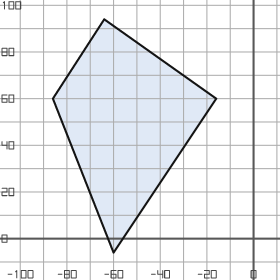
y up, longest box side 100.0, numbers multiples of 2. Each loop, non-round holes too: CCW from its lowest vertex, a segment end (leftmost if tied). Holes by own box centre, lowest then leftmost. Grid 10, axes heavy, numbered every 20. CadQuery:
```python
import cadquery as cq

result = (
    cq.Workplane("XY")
    .moveTo(-60.0, -6.0)
    .lineTo(-16.0, 60.0)
    .lineTo(-64.0, 94.0)
    .lineTo(-86.0, 60.0)
    .close()
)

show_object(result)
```